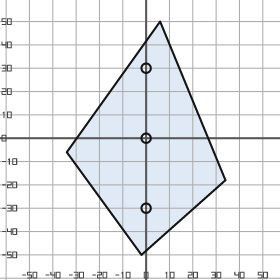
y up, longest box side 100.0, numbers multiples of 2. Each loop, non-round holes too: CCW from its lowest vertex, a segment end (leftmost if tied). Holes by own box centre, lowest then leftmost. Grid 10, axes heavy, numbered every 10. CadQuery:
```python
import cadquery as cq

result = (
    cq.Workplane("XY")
    .moveTo(-2.0, -50.0)
    .lineTo(34.0, -18.0)
    .lineTo(6.0, 50.0)
    .lineTo(-34.0, -6.0)
    .close()
    .moveTo(0.0, -30.0)
    .circle(2.0)
    .moveTo(0.0, 0.0)
    .circle(2.0)
    .moveTo(0.0, 30.0)
    .circle(2.0)
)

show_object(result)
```